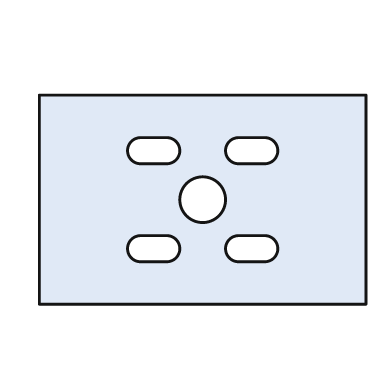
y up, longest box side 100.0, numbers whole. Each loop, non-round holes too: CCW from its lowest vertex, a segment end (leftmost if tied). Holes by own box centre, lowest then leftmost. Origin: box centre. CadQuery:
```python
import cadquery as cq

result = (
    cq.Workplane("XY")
    .moveTo(-50.0, -32.0)
    .lineTo(50.0, -32.0)
    .lineTo(50.0, 32.0)
    .lineTo(-50.0, 32.0)
    .close()
    .moveTo(-19.0, -19.0)
    .lineTo(-11.0, -19.0)
    .threePointArc((-7.0, -15.0), (-11.0, -11.0))
    .lineTo(-19.0, -11.0)
    .threePointArc((-23.0, -15.0), (-19.0, -19.0))
    .close()
    .moveTo(11.0, -19.0)
    .lineTo(19.0, -19.0)
    .threePointArc((23.0, -15.0), (19.0, -11.0))
    .lineTo(11.0, -11.0)
    .threePointArc((7.0, -15.0), (11.0, -19.0))
    .close()
    .moveTo(0.0, 0.0)
    .circle(7.0)
    .moveTo(-19.0, 11.0)
    .lineTo(-11.0, 11.0)
    .threePointArc((-7.0, 15.0), (-11.0, 19.0))
    .lineTo(-19.0, 19.0)
    .threePointArc((-23.0, 15.0), (-19.0, 11.0))
    .close()
    .moveTo(11.0, 11.0)
    .lineTo(19.0, 11.0)
    .threePointArc((23.0, 15.0), (19.0, 19.0))
    .lineTo(11.0, 19.0)
    .threePointArc((7.0, 15.0), (11.0, 11.0))
    .close()
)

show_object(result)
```